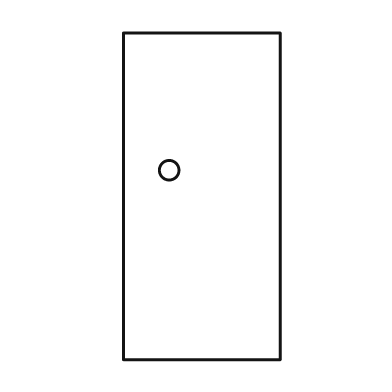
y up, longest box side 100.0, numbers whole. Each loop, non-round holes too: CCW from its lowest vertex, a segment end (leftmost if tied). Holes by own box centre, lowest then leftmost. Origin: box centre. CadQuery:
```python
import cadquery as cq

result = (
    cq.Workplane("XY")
    .moveTo(-24.0, -50.0)
    .lineTo(24.0, -50.0)
    .lineTo(24.0, 50.0)
    .lineTo(-24.0, 50.0)
    .close()
    .moveTo(-10.0, 8.0)
    .circle(3.0)
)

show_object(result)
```